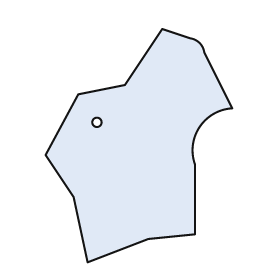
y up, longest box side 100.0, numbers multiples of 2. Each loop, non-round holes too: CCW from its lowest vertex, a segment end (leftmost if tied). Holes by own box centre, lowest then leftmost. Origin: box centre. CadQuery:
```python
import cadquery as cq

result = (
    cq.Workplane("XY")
    .moveTo(-22.0, -50.0)
    .lineTo(4.0, -40.0)
    .lineTo(24.0, -38.0)
    .lineTo(24.0, -8.0)
    .threePointArc((26.0, 8.0), (40.0, 16.0))
    .lineTo(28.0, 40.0)
    .threePointArc((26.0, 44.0), (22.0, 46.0))
    .lineTo(10.0, 50.0)
    .lineTo(-6.0, 26.0)
    .lineTo(-26.0, 22.0)
    .lineTo(-40.0, -4.0)
    .lineTo(-28.0, -22.0)
    .close()
    .moveTo(-18.0, 10.0)
    .circle(2.0)
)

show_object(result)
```